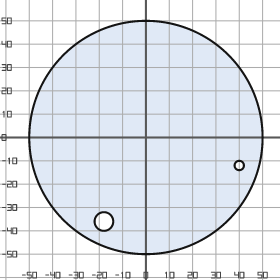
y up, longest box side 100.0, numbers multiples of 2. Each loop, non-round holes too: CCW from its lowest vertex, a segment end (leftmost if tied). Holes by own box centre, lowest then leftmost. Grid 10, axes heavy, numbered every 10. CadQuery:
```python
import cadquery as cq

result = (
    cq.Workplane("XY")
    .moveTo(0.0, 0.0)
    .circle(50.0)
    .moveTo(-18.0, -36.0)
    .circle(4.0)
    .moveTo(40.0, -12.0)
    .circle(2.0)
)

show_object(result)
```